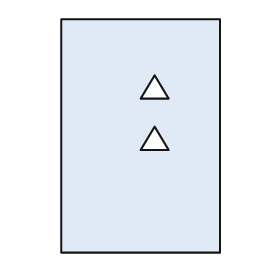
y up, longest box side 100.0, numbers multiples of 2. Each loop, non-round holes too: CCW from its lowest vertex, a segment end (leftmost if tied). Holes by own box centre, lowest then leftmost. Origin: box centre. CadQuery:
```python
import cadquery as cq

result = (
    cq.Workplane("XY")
    .moveTo(-34.0, -50.0)
    .lineTo(34.0, -50.0)
    .lineTo(34.0, 50.0)
    .lineTo(-34.0, 50.0)
    .close()
    .moveTo(0.0, -6.0)
    .lineTo(12.0, -6.0)
    .lineTo(6.0, 4.0)
    .close()
    .moveTo(0.0, 16.0)
    .lineTo(12.0, 16.0)
    .lineTo(6.0, 26.0)
    .close()
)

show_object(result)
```